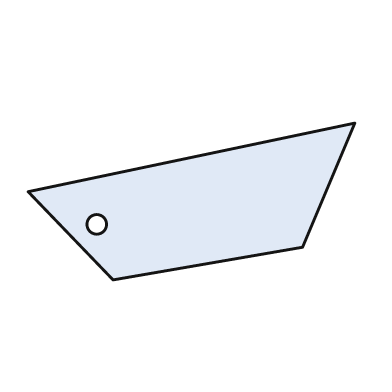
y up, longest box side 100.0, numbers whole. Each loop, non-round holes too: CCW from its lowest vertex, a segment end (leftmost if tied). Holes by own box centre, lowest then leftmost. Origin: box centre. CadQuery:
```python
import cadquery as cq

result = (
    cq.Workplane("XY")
    .moveTo(-24.0, -24.0)
    .lineTo(34.0, -14.0)
    .lineTo(50.0, 24.0)
    .lineTo(-50.0, 3.0)
    .close()
    .moveTo(-29.0, -7.0)
    .circle(3.0)
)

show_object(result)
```